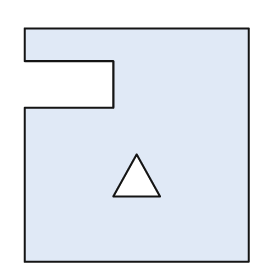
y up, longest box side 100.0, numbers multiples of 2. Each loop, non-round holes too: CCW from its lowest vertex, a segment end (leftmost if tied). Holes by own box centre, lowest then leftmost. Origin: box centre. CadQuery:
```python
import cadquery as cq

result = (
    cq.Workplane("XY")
    .moveTo(-48.0, -50.0)
    .lineTo(48.0, -50.0)
    .lineTo(48.0, 50.0)
    .lineTo(-48.0, 50.0)
    .lineTo(-48.0, 36.0)
    .lineTo(-10.0, 36.0)
    .lineTo(-10.0, 16.0)
    .lineTo(-48.0, 16.0)
    .close()
    .moveTo(-10.0, -22.0)
    .lineTo(10.0, -22.0)
    .lineTo(0.0, -4.0)
    .close()
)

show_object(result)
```